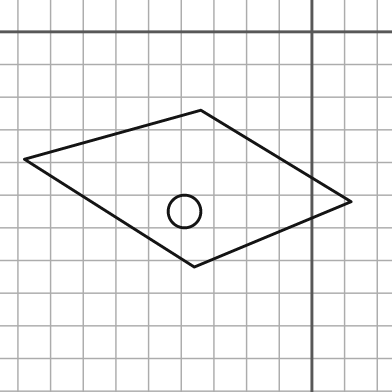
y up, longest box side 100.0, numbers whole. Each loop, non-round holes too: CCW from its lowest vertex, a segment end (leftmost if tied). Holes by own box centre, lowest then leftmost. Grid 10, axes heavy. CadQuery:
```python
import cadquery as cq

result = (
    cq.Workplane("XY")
    .moveTo(-36.0, -72.0)
    .lineTo(12.0, -52.0)
    .lineTo(-34.0, -24.0)
    .lineTo(-88.0, -39.0)
    .close()
    .moveTo(-39.0, -55.0)
    .circle(5.0)
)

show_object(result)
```